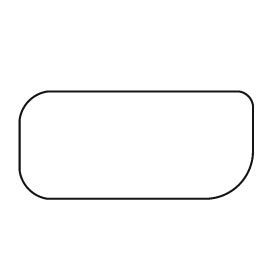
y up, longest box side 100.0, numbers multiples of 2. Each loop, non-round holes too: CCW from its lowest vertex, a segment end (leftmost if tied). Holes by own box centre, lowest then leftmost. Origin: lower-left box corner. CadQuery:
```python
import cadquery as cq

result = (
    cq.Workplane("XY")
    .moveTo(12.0, 0.0)
    .lineTo(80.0, 0.0)
    .threePointArc((94.0, 6.0), (100.0, 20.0))
    .lineTo(100.0, 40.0)
    .threePointArc((98.0, 44.0), (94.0, 46.0))
    .lineTo(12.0, 46.0)
    .threePointArc((4.0, 42.0), (0.0, 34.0))
    .lineTo(0.0, 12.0)
    .threePointArc((4.0, 4.0), (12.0, 0.0))
    .close()
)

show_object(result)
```